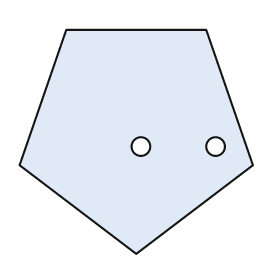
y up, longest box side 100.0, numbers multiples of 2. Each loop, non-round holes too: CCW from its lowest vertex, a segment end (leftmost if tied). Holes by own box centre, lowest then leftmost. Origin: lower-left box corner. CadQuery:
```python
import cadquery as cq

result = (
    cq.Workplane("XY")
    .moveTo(50.0, 0.0)
    .lineTo(100.0, 38.0)
    .lineTo(80.0, 96.0)
    .lineTo(20.0, 96.0)
    .lineTo(0.0, 38.0)
    .close()
    .moveTo(52.0, 46.0)
    .circle(4.0)
    .moveTo(84.0, 46.0)
    .circle(4.0)
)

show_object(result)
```